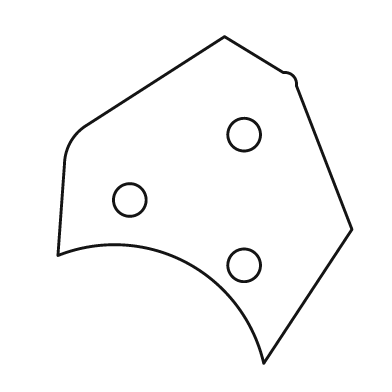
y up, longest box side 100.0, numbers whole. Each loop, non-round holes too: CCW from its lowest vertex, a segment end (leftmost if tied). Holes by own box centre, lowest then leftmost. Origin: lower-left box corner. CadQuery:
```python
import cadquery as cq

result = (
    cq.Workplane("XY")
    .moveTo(63.0, 0.0)
    .lineTo(90.0, 41.0)
    .lineTo(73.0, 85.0)
    .threePointArc((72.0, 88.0), (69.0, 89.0))
    .lineTo(51.0, 100.0)
    .lineTo(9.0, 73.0)
    .threePointArc((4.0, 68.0), (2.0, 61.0))
    .lineTo(0.0, 33.0)
    .threePointArc((39.0, 31.0), (63.0, 0.0))
    .close()
    .moveTo(57.0, 30.0)
    .circle(5.0)
    .moveTo(22.0, 50.0)
    .circle(5.0)
    .moveTo(57.0, 70.0)
    .circle(5.0)
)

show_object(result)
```